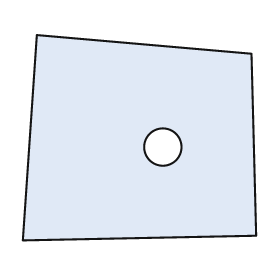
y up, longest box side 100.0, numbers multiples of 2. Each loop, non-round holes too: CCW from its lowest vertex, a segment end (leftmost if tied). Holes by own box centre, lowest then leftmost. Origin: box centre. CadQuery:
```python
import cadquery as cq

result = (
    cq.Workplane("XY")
    .moveTo(-50.0, -44.0)
    .lineTo(50.0, -42.0)
    .lineTo(48.0, 36.0)
    .lineTo(-44.0, 44.0)
    .close()
    .moveTo(10.0, -4.0)
    .circle(8.0)
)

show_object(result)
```